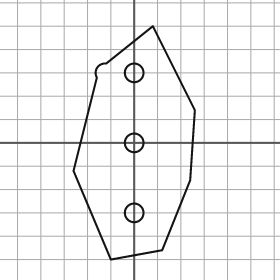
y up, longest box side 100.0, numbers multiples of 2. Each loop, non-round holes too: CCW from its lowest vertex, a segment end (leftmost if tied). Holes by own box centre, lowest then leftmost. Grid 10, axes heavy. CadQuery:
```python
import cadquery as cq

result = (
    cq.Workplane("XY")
    .moveTo(-10.0, -50.0)
    .lineTo(12.0, -46.0)
    .lineTo(24.0, -16.0)
    .lineTo(26.0, 14.0)
    .lineTo(8.0, 50.0)
    .lineTo(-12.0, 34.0)
    .threePointArc((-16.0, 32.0), (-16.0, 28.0))
    .lineTo(-26.0, -12.0)
    .close()
    .moveTo(0.0, -30.0)
    .circle(4.0)
    .moveTo(0.0, 0.0)
    .circle(4.0)
    .moveTo(0.0, 30.0)
    .circle(4.0)
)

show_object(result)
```